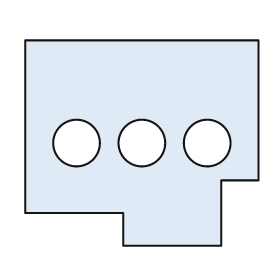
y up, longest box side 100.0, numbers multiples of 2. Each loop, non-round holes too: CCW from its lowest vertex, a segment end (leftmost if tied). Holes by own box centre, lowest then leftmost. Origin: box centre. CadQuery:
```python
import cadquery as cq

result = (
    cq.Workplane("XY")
    .moveTo(-8.0, -44.0)
    .lineTo(34.0, -44.0)
    .lineTo(34.0, -16.0)
    .lineTo(50.0, -16.0)
    .lineTo(50.0, 44.0)
    .lineTo(-50.0, 44.0)
    .lineTo(-50.0, -30.0)
    .lineTo(-8.0, -30.0)
    .close()
    .moveTo(-28.0, 0.0)
    .circle(10.0)
    .moveTo(0.0, 0.0)
    .circle(10.0)
    .moveTo(28.0, 0.0)
    .circle(10.0)
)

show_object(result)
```